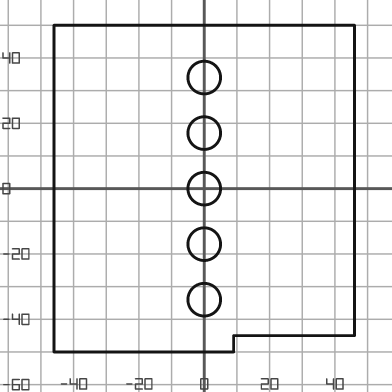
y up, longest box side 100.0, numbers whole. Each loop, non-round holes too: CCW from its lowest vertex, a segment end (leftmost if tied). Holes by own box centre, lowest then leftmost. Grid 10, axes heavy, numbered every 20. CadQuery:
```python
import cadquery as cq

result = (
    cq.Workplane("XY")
    .moveTo(-46.0, -50.0)
    .lineTo(9.0, -50.0)
    .lineTo(9.0, -45.0)
    .lineTo(46.0, -45.0)
    .lineTo(46.0, 50.0)
    .lineTo(-46.0, 50.0)
    .close()
    .moveTo(0.0, -34.0)
    .circle(5.0)
    .moveTo(0.0, -17.0)
    .circle(5.0)
    .moveTo(0.0, 0.0)
    .circle(5.0)
    .moveTo(0.0, 17.0)
    .circle(5.0)
    .moveTo(0.0, 34.0)
    .circle(5.0)
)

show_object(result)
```